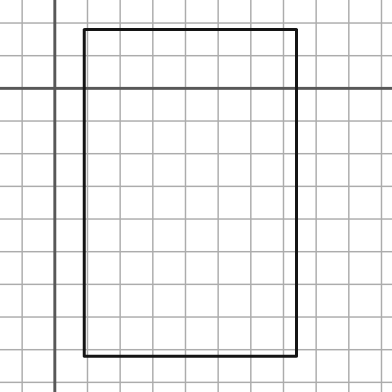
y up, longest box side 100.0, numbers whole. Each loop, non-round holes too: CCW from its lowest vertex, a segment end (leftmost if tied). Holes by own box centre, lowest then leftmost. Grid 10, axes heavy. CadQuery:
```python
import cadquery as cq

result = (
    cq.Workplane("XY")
    .moveTo(9.0, -82.0)
    .lineTo(74.0, -82.0)
    .lineTo(74.0, 18.0)
    .lineTo(9.0, 18.0)
    .close()
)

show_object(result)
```